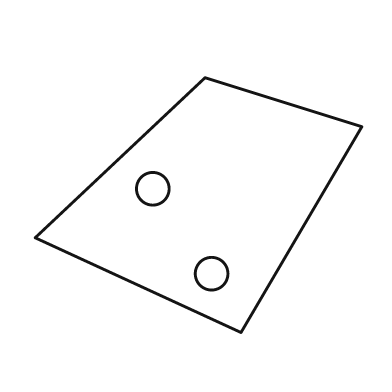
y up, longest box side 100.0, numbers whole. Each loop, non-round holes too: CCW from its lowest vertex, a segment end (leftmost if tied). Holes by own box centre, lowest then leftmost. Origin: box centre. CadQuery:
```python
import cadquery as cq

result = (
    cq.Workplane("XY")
    .moveTo(13.0, -39.0)
    .lineTo(50.0, 24.0)
    .lineTo(2.0, 39.0)
    .lineTo(-50.0, -10.0)
    .close()
    .moveTo(4.0, -21.0)
    .circle(5.0)
    .moveTo(-14.0, 5.0)
    .circle(5.0)
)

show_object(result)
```